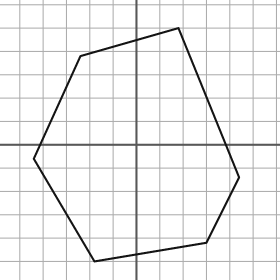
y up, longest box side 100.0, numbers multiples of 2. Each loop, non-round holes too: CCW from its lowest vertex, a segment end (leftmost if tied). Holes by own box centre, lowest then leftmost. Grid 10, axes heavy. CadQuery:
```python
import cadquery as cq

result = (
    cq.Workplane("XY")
    .moveTo(-18.0, -50.0)
    .lineTo(30.0, -42.0)
    .lineTo(44.0, -14.0)
    .lineTo(18.0, 50.0)
    .lineTo(-24.0, 38.0)
    .lineTo(-44.0, -6.0)
    .close()
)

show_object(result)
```